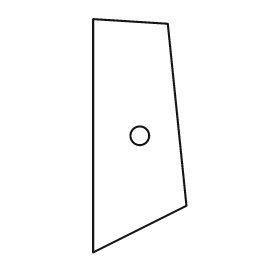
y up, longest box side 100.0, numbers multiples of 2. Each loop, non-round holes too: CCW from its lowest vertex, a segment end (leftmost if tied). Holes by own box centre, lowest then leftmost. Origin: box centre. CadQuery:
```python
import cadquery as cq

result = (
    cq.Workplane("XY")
    .moveTo(-20.0, -50.0)
    .lineTo(20.0, -30.0)
    .lineTo(12.0, 48.0)
    .lineTo(-20.0, 50.0)
    .close()
    .moveTo(0.0, 0.0)
    .circle(4.0)
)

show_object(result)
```